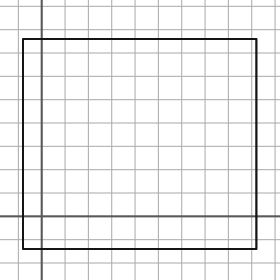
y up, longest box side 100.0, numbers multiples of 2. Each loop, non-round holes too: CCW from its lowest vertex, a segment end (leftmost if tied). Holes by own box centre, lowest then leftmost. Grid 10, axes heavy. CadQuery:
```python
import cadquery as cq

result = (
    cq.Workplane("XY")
    .moveTo(-8.0, -14.0)
    .lineTo(92.0, -14.0)
    .lineTo(92.0, 76.0)
    .lineTo(-8.0, 76.0)
    .close()
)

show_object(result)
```